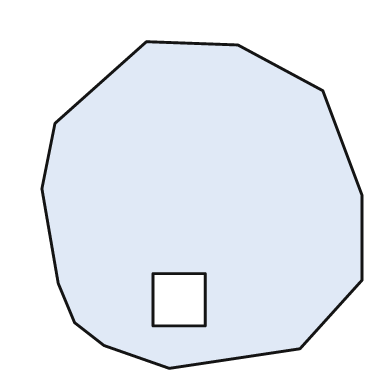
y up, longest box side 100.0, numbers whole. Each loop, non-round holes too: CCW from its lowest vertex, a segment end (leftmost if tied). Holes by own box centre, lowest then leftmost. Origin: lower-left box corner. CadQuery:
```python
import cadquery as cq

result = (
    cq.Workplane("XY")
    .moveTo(39.0, 0.0)
    .lineTo(79.0, 6.0)
    .lineTo(98.0, 27.0)
    .lineTo(98.0, 53.0)
    .lineTo(86.0, 85.0)
    .lineTo(60.0, 99.0)
    .lineTo(32.0, 100.0)
    .lineTo(4.0, 75.0)
    .lineTo(0.0, 55.0)
    .lineTo(5.0, 26.0)
    .lineTo(10.0, 14.0)
    .lineTo(19.0, 7.0)
    .close()
    .moveTo(34.0, 13.0)
    .lineTo(50.0, 13.0)
    .lineTo(50.0, 29.0)
    .lineTo(34.0, 29.0)
    .close()
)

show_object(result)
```